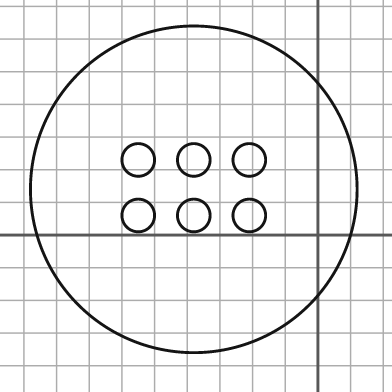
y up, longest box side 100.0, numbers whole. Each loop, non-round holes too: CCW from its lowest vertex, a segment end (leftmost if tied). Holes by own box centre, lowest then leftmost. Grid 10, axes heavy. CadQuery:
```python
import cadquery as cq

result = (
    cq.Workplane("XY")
    .moveTo(-38.0, 14.0)
    .circle(50.0)
    .moveTo(-55.0, 6.0)
    .circle(5.0)
    .moveTo(-38.0, 6.0)
    .circle(5.0)
    .moveTo(-21.0, 6.0)
    .circle(5.0)
    .moveTo(-55.0, 23.0)
    .circle(5.0)
    .moveTo(-38.0, 23.0)
    .circle(5.0)
    .moveTo(-21.0, 23.0)
    .circle(5.0)
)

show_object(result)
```